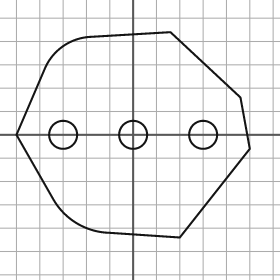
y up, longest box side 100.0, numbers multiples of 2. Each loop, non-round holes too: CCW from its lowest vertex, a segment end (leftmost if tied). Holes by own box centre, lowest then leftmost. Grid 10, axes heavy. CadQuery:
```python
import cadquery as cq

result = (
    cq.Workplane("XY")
    .moveTo(20.0, -44.0)
    .lineTo(50.0, -6.0)
    .lineTo(46.0, 16.0)
    .lineTo(16.0, 44.0)
    .lineTo(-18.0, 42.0)
    .threePointArc((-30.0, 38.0), (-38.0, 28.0))
    .lineTo(-50.0, 0.0)
    .lineTo(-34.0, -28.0)
    .threePointArc((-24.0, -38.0), (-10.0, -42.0))
    .close()
    .moveTo(-30.0, 0.0)
    .circle(6.0)
    .moveTo(0.0, 0.0)
    .circle(6.0)
    .moveTo(30.0, 0.0)
    .circle(6.0)
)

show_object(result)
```